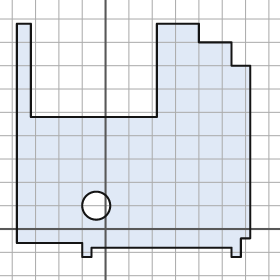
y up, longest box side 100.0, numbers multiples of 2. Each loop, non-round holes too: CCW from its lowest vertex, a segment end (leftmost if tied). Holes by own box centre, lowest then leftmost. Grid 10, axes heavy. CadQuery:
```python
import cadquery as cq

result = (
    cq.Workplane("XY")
    .moveTo(-10.0, -12.0)
    .lineTo(-6.0, -12.0)
    .lineTo(-6.0, -8.0)
    .lineTo(54.0, -8.0)
    .lineTo(54.0, -12.0)
    .lineTo(58.0, -12.0)
    .lineTo(58.0, -4.0)
    .lineTo(62.0, -4.0)
    .lineTo(62.0, 70.0)
    .lineTo(54.0, 70.0)
    .lineTo(54.0, 80.0)
    .lineTo(40.0, 80.0)
    .lineTo(40.0, 88.0)
    .lineTo(22.0, 88.0)
    .lineTo(22.0, 48.0)
    .lineTo(-32.0, 48.0)
    .lineTo(-32.0, 88.0)
    .lineTo(-38.0, 88.0)
    .lineTo(-38.0, -6.0)
    .lineTo(-10.0, -6.0)
    .close()
    .moveTo(-4.0, 10.0)
    .circle(6.0)
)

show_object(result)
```